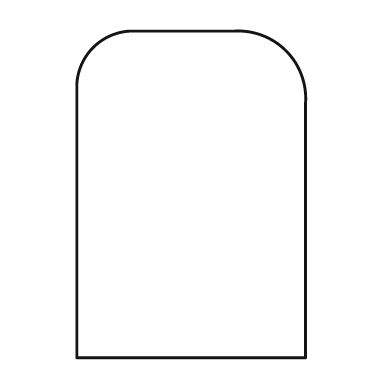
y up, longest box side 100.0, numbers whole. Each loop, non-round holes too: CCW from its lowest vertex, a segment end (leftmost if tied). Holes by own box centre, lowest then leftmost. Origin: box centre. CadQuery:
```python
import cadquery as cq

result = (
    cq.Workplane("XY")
    .moveTo(-35.0, -50.0)
    .lineTo(35.0, -50.0)
    .lineTo(35.0, 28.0)
    .threePointArc((29.0, 44.0), (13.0, 50.0))
    .lineTo(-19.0, 50.0)
    .threePointArc((-30.0, 45.0), (-35.0, 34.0))
    .close()
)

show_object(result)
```